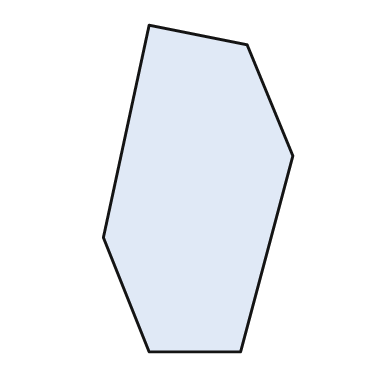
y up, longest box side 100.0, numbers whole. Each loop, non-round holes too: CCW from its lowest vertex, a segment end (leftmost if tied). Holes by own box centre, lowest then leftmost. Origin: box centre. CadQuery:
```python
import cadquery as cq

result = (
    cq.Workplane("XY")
    .moveTo(-15.0, -50.0)
    .lineTo(13.0, -50.0)
    .lineTo(29.0, 10.0)
    .lineTo(15.0, 44.0)
    .lineTo(-15.0, 50.0)
    .lineTo(-29.0, -15.0)
    .close()
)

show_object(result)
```